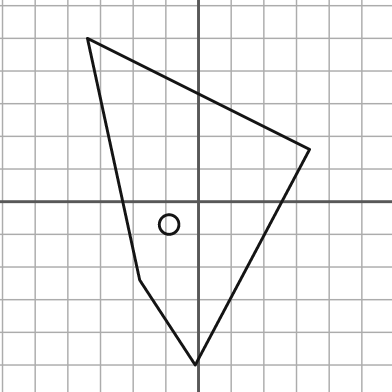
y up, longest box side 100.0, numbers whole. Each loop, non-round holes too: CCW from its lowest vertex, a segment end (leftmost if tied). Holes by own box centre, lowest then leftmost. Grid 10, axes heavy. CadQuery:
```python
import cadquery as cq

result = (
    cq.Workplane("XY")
    .moveTo(-1.0, -50.0)
    .lineTo(34.0, 16.0)
    .lineTo(-34.0, 50.0)
    .lineTo(-18.0, -24.0)
    .close()
    .moveTo(-9.0, -7.0)
    .circle(3.0)
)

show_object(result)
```